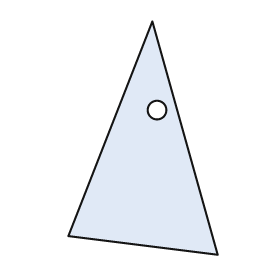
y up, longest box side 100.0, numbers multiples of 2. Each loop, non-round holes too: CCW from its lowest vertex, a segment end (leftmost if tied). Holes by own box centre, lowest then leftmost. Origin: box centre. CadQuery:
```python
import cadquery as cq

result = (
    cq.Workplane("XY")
    .moveTo(32.0, -50.0)
    .lineTo(4.0, 50.0)
    .lineTo(-32.0, -42.0)
    .close()
    .moveTo(6.0, 12.0)
    .circle(4.0)
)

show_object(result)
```